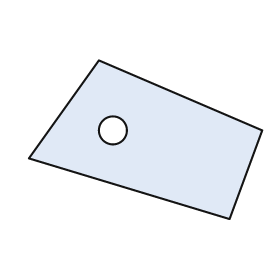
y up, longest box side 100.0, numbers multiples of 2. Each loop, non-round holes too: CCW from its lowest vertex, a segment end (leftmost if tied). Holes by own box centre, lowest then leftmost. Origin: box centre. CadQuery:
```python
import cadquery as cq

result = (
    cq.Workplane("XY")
    .moveTo(36.0, -34.0)
    .lineTo(50.0, 4.0)
    .lineTo(-20.0, 34.0)
    .lineTo(-50.0, -8.0)
    .close()
    .moveTo(-14.0, 4.0)
    .circle(6.0)
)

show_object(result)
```